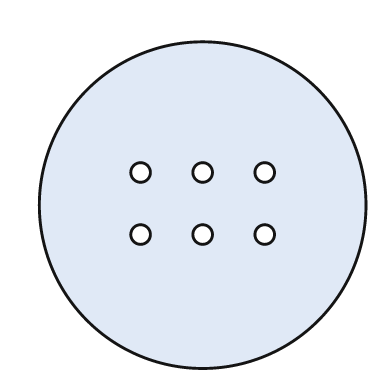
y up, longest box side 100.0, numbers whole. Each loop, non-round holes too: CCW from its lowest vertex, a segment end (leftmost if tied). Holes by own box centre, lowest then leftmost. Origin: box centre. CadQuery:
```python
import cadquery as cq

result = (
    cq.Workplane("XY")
    .moveTo(0.0, 0.0)
    .circle(50.0)
    .moveTo(-19.0, -9.0)
    .circle(3.0)
    .moveTo(0.0, -9.0)
    .circle(3.0)
    .moveTo(19.0, -9.0)
    .circle(3.0)
    .moveTo(-19.0, 10.0)
    .circle(3.0)
    .moveTo(0.0, 10.0)
    .circle(3.0)
    .moveTo(19.0, 10.0)
    .circle(3.0)
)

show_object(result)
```